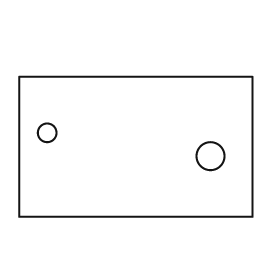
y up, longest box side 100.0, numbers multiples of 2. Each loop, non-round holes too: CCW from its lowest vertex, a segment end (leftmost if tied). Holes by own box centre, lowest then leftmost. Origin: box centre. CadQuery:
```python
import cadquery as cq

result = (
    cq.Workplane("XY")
    .moveTo(-50.0, -30.0)
    .lineTo(50.0, -30.0)
    .lineTo(50.0, 30.0)
    .lineTo(-50.0, 30.0)
    .close()
    .moveTo(32.0, -4.0)
    .circle(6.0)
    .moveTo(-38.0, 6.0)
    .circle(4.0)
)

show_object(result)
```